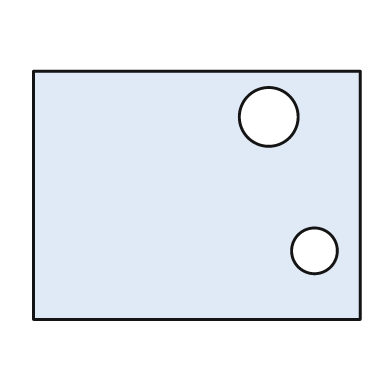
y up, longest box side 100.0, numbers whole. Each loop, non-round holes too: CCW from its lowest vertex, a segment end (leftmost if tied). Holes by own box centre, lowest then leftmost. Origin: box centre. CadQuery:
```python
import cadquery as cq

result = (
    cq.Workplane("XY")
    .moveTo(-50.0, -38.0)
    .lineTo(50.0, -38.0)
    .lineTo(50.0, 38.0)
    .lineTo(-50.0, 38.0)
    .close()
    .moveTo(36.0, -17.0)
    .circle(7.0)
    .moveTo(22.0, 24.0)
    .circle(9.0)
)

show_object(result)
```